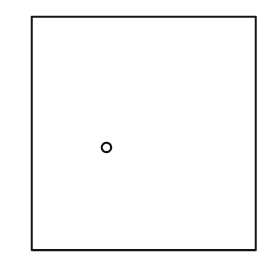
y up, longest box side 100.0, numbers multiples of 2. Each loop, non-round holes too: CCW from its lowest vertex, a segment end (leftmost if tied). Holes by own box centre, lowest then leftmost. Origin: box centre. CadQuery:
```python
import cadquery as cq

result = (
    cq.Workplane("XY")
    .moveTo(-48.0, -50.0)
    .lineTo(48.0, -50.0)
    .lineTo(48.0, 50.0)
    .lineTo(-48.0, 50.0)
    .close()
    .moveTo(-16.0, -6.0)
    .circle(2.0)
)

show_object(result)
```